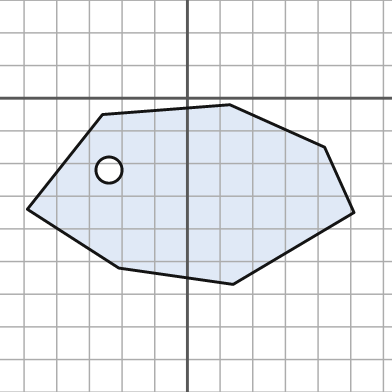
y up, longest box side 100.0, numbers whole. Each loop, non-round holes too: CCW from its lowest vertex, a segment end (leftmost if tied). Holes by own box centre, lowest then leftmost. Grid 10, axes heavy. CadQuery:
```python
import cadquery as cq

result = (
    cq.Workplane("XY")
    .moveTo(14.0, -57.0)
    .lineTo(51.0, -35.0)
    .lineTo(42.0, -15.0)
    .lineTo(13.0, -2.0)
    .lineTo(-26.0, -5.0)
    .lineTo(-49.0, -34.0)
    .lineTo(-21.0, -52.0)
    .close()
    .moveTo(-24.0, -22.0)
    .circle(4.0)
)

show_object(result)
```